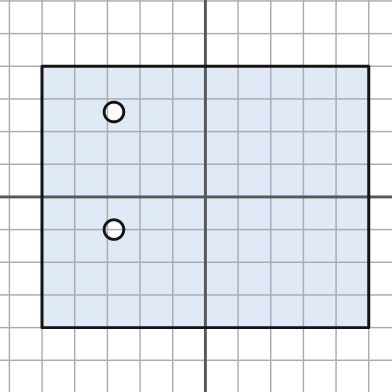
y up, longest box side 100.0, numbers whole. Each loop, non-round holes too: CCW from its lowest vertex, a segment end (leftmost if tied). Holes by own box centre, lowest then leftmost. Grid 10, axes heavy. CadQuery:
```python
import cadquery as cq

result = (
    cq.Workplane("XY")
    .moveTo(-50.0, -40.0)
    .lineTo(50.0, -40.0)
    .lineTo(50.0, 40.0)
    .lineTo(-50.0, 40.0)
    .close()
    .moveTo(-28.0, -10.0)
    .circle(3.0)
    .moveTo(-28.0, 26.0)
    .circle(3.0)
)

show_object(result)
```